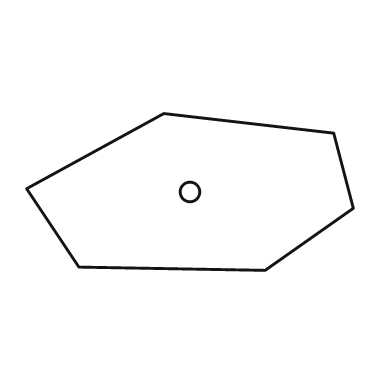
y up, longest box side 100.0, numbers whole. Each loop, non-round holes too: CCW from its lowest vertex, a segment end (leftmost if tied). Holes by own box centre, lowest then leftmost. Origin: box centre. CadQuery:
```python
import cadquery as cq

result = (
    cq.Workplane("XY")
    .moveTo(23.0, -24.0)
    .lineTo(50.0, -5.0)
    .lineTo(44.0, 18.0)
    .lineTo(-8.0, 24.0)
    .lineTo(-50.0, 1.0)
    .lineTo(-34.0, -23.0)
    .close()
    .moveTo(0.0, 0.0)
    .circle(3.0)
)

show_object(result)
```